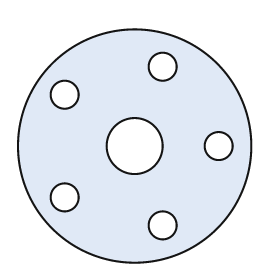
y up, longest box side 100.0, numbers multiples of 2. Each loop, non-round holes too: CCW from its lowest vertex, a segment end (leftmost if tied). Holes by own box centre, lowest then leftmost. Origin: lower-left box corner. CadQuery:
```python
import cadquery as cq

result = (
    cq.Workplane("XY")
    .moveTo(50.0, 50.0)
    .circle(50.0)
    .moveTo(62.0, 16.0)
    .circle(6.0)
    .moveTo(20.0, 28.0)
    .circle(6.0)
    .moveTo(50.0, 50.0)
    .circle(12.0)
    .moveTo(86.0, 50.0)
    .circle(6.0)
    .moveTo(20.0, 72.0)
    .circle(6.0)
    .moveTo(62.0, 84.0)
    .circle(6.0)
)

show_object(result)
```